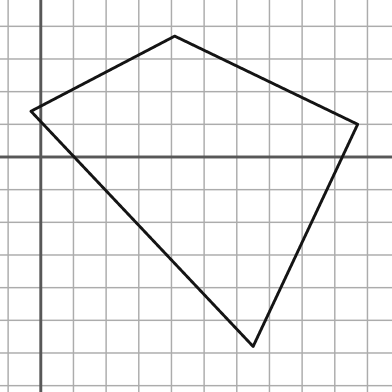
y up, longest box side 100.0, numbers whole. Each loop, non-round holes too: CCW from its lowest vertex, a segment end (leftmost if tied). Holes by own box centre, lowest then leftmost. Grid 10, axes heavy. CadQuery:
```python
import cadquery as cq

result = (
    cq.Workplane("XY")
    .moveTo(65.0, -58.0)
    .lineTo(97.0, 10.0)
    .lineTo(41.0, 37.0)
    .lineTo(-3.0, 14.0)
    .close()
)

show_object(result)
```